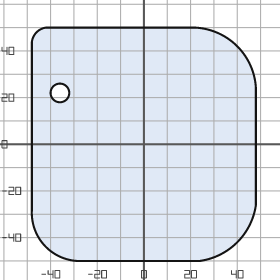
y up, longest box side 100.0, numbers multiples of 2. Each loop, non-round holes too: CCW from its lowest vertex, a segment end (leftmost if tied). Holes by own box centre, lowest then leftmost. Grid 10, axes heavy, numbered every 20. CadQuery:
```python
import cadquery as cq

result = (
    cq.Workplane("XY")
    .moveTo(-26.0, -50.0)
    .lineTo(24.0, -50.0)
    .threePointArc((40.0, -42.0), (48.0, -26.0))
    .lineTo(48.0, 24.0)
    .threePointArc((40.0, 42.0), (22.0, 50.0))
    .lineTo(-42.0, 50.0)
    .threePointArc((-46.0, 48.0), (-48.0, 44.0))
    .lineTo(-48.0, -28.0)
    .threePointArc((-42.0, -44.0), (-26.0, -50.0))
    .close()
    .moveTo(-36.0, 22.0)
    .circle(4.0)
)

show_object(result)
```